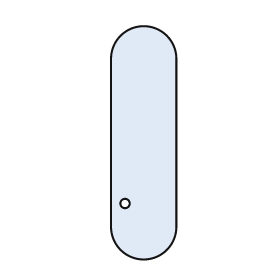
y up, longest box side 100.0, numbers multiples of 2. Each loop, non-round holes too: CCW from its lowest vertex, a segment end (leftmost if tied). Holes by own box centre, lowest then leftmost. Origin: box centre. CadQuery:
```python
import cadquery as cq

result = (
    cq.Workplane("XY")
    .moveTo(-14.0, -36.0)
    .threePointArc((0.0, -50.0), (14.0, -36.0))
    .lineTo(14.0, 36.0)
    .threePointArc((0.0, 50.0), (-14.0, 36.0))
    .close()
    .moveTo(-8.0, -26.0)
    .circle(2.0)
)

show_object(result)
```